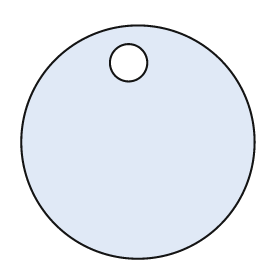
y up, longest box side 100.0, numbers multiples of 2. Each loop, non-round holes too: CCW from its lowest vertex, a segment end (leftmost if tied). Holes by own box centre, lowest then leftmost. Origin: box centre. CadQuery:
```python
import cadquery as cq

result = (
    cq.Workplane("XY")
    .moveTo(0.0, 0.0)
    .circle(50.0)
    .moveTo(-4.0, 34.0)
    .circle(8.0)
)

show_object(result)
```